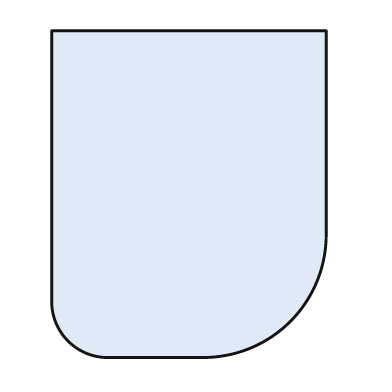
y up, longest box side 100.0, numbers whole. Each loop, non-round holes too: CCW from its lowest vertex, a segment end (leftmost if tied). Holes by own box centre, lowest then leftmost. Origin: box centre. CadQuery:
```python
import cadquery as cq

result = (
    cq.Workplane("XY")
    .moveTo(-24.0, -50.0)
    .lineTo(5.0, -50.0)
    .threePointArc((31.0, -39.0), (42.0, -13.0))
    .lineTo(42.0, 50.0)
    .lineTo(-42.0, 50.0)
    .lineTo(-42.0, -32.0)
    .threePointArc((-37.0, -45.0), (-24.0, -50.0))
    .close()
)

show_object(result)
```